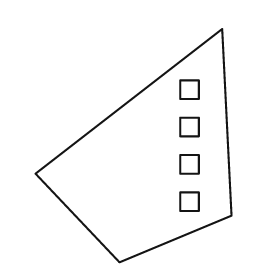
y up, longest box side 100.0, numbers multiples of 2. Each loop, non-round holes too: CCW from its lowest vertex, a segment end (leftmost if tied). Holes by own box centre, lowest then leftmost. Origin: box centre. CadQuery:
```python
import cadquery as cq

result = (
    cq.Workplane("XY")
    .moveTo(-6.0, -50.0)
    .lineTo(42.0, -30.0)
    .lineTo(38.0, 50.0)
    .lineTo(-42.0, -12.0)
    .close()
    .moveTo(20.0, -28.0)
    .lineTo(28.0, -28.0)
    .lineTo(28.0, -20.0)
    .lineTo(20.0, -20.0)
    .close()
    .moveTo(20.0, -12.0)
    .lineTo(28.0, -12.0)
    .lineTo(28.0, -4.0)
    .lineTo(20.0, -4.0)
    .close()
    .moveTo(20.0, 4.0)
    .lineTo(28.0, 4.0)
    .lineTo(28.0, 12.0)
    .lineTo(20.0, 12.0)
    .close()
    .moveTo(20.0, 20.0)
    .lineTo(28.0, 20.0)
    .lineTo(28.0, 28.0)
    .lineTo(20.0, 28.0)
    .close()
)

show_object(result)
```